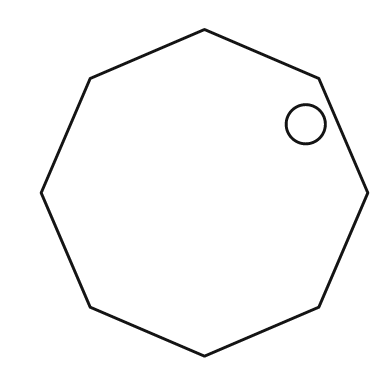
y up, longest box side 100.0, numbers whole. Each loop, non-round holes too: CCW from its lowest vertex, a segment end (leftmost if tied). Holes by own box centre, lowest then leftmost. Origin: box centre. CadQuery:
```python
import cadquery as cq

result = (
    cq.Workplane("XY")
    .moveTo(0.0, -50.0)
    .lineTo(35.0, -35.0)
    .lineTo(50.0, 0.0)
    .lineTo(35.0, 35.0)
    .lineTo(0.0, 50.0)
    .lineTo(-35.0, 35.0)
    .lineTo(-50.0, 0.0)
    .lineTo(-35.0, -35.0)
    .close()
    .moveTo(31.0, 21.0)
    .circle(6.0)
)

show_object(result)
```